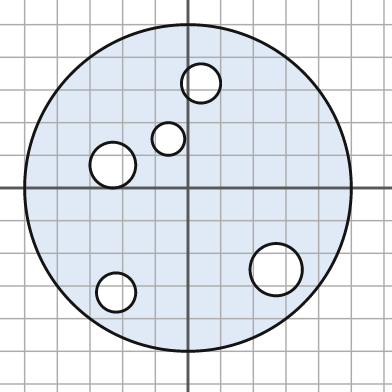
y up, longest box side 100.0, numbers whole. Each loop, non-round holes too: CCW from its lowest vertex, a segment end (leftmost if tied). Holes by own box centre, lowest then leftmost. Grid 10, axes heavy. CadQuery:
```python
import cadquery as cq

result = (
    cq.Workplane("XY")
    .moveTo(0.0, 0.0)
    .circle(50.0)
    .moveTo(-22.0, -32.0)
    .circle(6.0)
    .moveTo(27.0, -25.0)
    .circle(8.0)
    .moveTo(-23.0, 7.0)
    .circle(7.0)
    .moveTo(-6.0, 15.0)
    .circle(5.0)
    .moveTo(4.0, 32.0)
    .circle(6.0)
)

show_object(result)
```